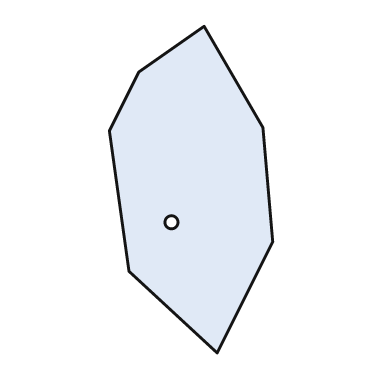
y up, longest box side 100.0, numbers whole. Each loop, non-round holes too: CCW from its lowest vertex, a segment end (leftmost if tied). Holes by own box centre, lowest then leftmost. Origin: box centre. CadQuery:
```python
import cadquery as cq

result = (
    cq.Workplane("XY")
    .moveTo(8.0, -50.0)
    .lineTo(25.0, -16.0)
    .lineTo(22.0, 19.0)
    .lineTo(4.0, 50.0)
    .lineTo(-16.0, 36.0)
    .lineTo(-25.0, 18.0)
    .lineTo(-19.0, -25.0)
    .close()
    .moveTo(-6.0, -10.0)
    .circle(2.0)
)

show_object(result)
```